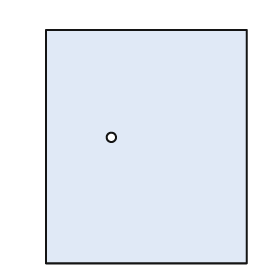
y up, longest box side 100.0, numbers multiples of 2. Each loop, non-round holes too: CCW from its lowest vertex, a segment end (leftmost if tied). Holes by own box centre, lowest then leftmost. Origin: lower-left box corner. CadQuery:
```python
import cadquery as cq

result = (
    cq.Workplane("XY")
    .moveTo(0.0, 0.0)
    .lineTo(86.0, 0.0)
    .lineTo(86.0, 100.0)
    .lineTo(0.0, 100.0)
    .close()
    .moveTo(28.0, 54.0)
    .circle(2.0)
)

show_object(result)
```